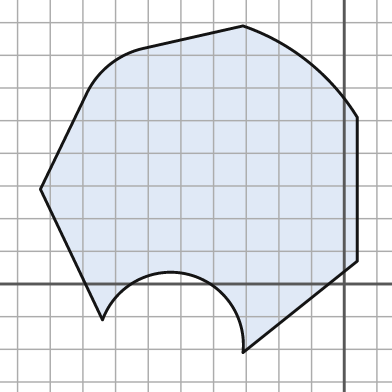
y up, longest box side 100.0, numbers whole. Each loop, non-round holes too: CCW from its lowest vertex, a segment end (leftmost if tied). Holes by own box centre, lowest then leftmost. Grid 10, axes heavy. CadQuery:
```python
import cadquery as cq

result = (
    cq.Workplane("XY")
    .moveTo(-31.0, -21.0)
    .lineTo(4.0, 7.0)
    .lineTo(4.0, 51.0)
    .threePointArc((-11.0, 68.0), (-31.0, 79.0))
    .lineTo(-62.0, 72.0)
    .threePointArc((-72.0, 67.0), (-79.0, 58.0))
    .lineTo(-93.0, 29.0)
    .lineTo(-74.0, -11.0)
    .threePointArc((-48.0, 3.0), (-31.0, -21.0))
    .close()
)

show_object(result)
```